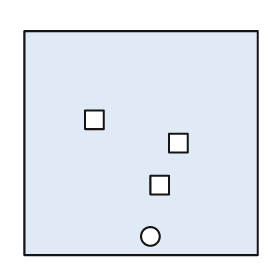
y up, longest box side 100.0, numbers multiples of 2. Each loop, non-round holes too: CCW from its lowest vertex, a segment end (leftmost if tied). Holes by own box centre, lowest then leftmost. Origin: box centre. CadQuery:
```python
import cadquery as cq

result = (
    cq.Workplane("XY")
    .moveTo(-50.0, -48.0)
    .lineTo(50.0, -48.0)
    .lineTo(50.0, 48.0)
    .lineTo(-50.0, 48.0)
    .close()
    .moveTo(4.0, -40.0)
    .circle(4.0)
    .moveTo(4.0, -22.0)
    .lineTo(12.0, -22.0)
    .lineTo(12.0, -14.0)
    .lineTo(4.0, -14.0)
    .close()
    .moveTo(12.0, -4.0)
    .lineTo(20.0, -4.0)
    .lineTo(20.0, 4.0)
    .lineTo(12.0, 4.0)
    .close()
    .moveTo(-24.0, 6.0)
    .lineTo(-16.0, 6.0)
    .lineTo(-16.0, 14.0)
    .lineTo(-24.0, 14.0)
    .close()
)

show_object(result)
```